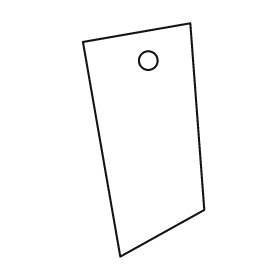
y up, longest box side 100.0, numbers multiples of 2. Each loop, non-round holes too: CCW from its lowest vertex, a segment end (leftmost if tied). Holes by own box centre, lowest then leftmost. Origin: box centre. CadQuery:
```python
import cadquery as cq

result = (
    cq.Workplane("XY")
    .moveTo(-10.0, -50.0)
    .lineTo(26.0, -30.0)
    .lineTo(20.0, 50.0)
    .lineTo(-26.0, 42.0)
    .close()
    .moveTo(2.0, 34.0)
    .circle(4.0)
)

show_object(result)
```